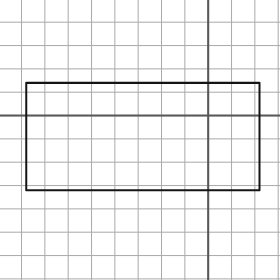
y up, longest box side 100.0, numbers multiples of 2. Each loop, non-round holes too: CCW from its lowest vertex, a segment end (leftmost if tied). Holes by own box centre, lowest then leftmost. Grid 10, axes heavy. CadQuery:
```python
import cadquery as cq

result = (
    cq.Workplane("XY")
    .moveTo(-78.0, -32.0)
    .lineTo(22.0, -32.0)
    .lineTo(22.0, 14.0)
    .lineTo(-78.0, 14.0)
    .close()
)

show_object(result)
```